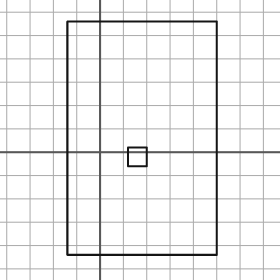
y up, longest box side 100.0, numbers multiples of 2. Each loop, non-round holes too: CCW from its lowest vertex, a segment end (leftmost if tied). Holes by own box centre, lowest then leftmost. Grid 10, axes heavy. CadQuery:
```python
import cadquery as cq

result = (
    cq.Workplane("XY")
    .moveTo(-14.0, -44.0)
    .lineTo(50.0, -44.0)
    .lineTo(50.0, 56.0)
    .lineTo(-14.0, 56.0)
    .close()
    .moveTo(12.0, -6.0)
    .lineTo(20.0, -6.0)
    .lineTo(20.0, 2.0)
    .lineTo(12.0, 2.0)
    .close()
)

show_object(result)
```